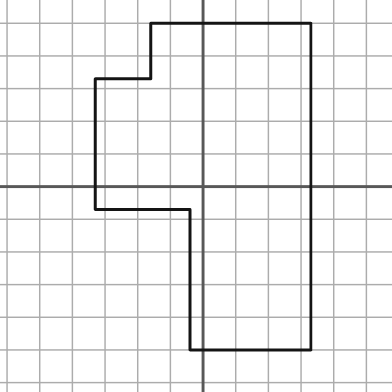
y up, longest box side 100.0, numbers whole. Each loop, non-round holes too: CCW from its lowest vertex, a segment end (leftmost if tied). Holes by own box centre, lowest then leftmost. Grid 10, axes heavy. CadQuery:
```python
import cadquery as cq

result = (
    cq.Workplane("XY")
    .moveTo(-4.0, -50.0)
    .lineTo(33.0, -50.0)
    .lineTo(33.0, 50.0)
    .lineTo(-16.0, 50.0)
    .lineTo(-16.0, 33.0)
    .lineTo(-33.0, 33.0)
    .lineTo(-33.0, -7.0)
    .lineTo(-4.0, -7.0)
    .close()
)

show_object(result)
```